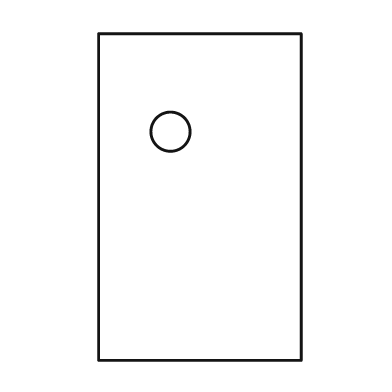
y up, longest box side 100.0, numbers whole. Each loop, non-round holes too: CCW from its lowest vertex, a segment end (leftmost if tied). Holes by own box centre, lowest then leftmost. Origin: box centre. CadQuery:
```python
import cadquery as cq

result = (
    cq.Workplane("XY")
    .moveTo(-31.0, -50.0)
    .lineTo(31.0, -50.0)
    .lineTo(31.0, 50.0)
    .lineTo(-31.0, 50.0)
    .close()
    .moveTo(-9.0, 20.0)
    .circle(6.0)
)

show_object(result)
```